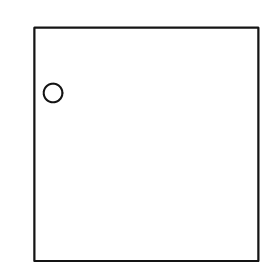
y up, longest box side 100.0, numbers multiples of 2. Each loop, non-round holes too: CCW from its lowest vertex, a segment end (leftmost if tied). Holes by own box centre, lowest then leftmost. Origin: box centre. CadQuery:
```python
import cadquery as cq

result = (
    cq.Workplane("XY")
    .moveTo(-48.0, -50.0)
    .lineTo(48.0, -50.0)
    .lineTo(48.0, 50.0)
    .lineTo(-48.0, 50.0)
    .close()
    .moveTo(-40.0, 22.0)
    .circle(4.0)
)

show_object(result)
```